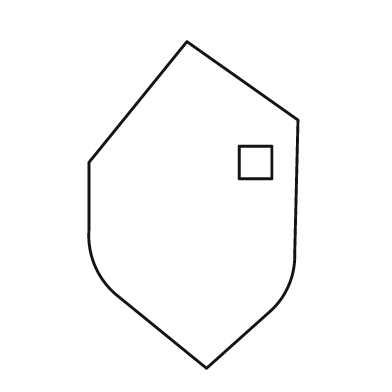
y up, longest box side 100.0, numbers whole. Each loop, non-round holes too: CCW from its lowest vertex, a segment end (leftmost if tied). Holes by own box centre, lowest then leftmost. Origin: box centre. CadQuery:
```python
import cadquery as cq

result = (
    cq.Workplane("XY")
    .moveTo(4.0, -50.0)
    .lineTo(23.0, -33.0)
    .threePointArc((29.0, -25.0), (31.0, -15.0))
    .lineTo(32.0, 26.0)
    .lineTo(-2.0, 50.0)
    .lineTo(-32.0, 13.0)
    .lineTo(-32.0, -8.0)
    .threePointArc((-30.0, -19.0), (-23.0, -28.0))
    .close()
    .moveTo(14.0, 8.0)
    .lineTo(24.0, 8.0)
    .lineTo(24.0, 18.0)
    .lineTo(14.0, 18.0)
    .close()
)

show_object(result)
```